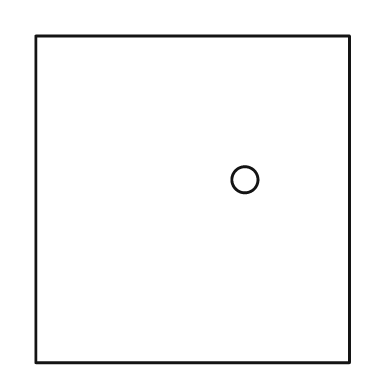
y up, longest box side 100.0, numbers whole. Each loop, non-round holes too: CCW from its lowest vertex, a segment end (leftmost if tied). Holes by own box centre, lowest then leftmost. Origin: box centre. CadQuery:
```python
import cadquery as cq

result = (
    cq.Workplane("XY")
    .moveTo(-48.0, -50.0)
    .lineTo(48.0, -50.0)
    .lineTo(48.0, 50.0)
    .lineTo(-48.0, 50.0)
    .close()
    .moveTo(16.0, 6.0)
    .circle(4.0)
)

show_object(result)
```